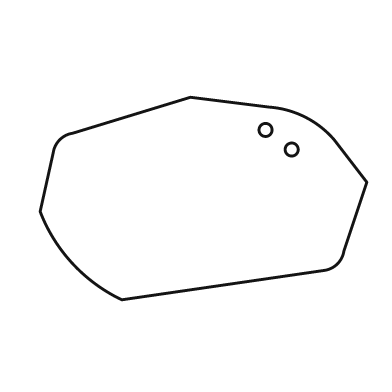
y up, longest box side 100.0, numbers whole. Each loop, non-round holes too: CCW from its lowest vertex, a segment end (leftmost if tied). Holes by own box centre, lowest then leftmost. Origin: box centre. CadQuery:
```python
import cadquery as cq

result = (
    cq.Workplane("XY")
    .moveTo(-25.0, -31.0)
    .lineTo(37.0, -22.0)
    .threePointArc((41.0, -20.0), (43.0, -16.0))
    .lineTo(50.0, 5.0)
    .lineTo(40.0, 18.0)
    .threePointArc((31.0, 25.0), (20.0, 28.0))
    .lineTo(-4.0, 31.0)
    .lineTo(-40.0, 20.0)
    .threePointArc((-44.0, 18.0), (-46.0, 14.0))
    .lineTo(-50.0, -4.0)
    .threePointArc((-40.0, -20.0), (-25.0, -31.0))
    .close()
    .moveTo(27.0, 15.0)
    .circle(2.0)
    .moveTo(19.0, 21.0)
    .circle(2.0)
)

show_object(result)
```